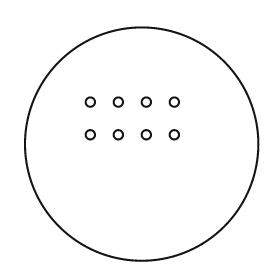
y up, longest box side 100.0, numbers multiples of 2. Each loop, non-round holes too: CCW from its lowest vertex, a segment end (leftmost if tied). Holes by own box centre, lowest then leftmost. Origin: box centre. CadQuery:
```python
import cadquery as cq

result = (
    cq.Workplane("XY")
    .moveTo(0.0, 0.0)
    .circle(50.0)
    .moveTo(-22.0, 4.0)
    .circle(2.0)
    .moveTo(-10.0, 4.0)
    .circle(2.0)
    .moveTo(2.0, 4.0)
    .circle(2.0)
    .moveTo(14.0, 4.0)
    .circle(2.0)
    .moveTo(-22.0, 18.0)
    .circle(2.0)
    .moveTo(-10.0, 18.0)
    .circle(2.0)
    .moveTo(2.0, 18.0)
    .circle(2.0)
    .moveTo(14.0, 18.0)
    .circle(2.0)
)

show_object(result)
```